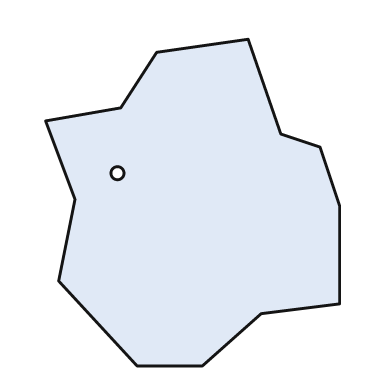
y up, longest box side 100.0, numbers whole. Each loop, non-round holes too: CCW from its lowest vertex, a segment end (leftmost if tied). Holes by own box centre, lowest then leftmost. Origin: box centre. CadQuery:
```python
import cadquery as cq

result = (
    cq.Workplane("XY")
    .moveTo(-17.0, -50.0)
    .lineTo(3.0, -50.0)
    .lineTo(21.0, -34.0)
    .lineTo(45.0, -31.0)
    .lineTo(45.0, -1.0)
    .lineTo(39.0, 17.0)
    .lineTo(27.0, 21.0)
    .lineTo(17.0, 50.0)
    .lineTo(-11.0, 46.0)
    .lineTo(-22.0, 29.0)
    .lineTo(-45.0, 25.0)
    .lineTo(-36.0, 1.0)
    .lineTo(-41.0, -24.0)
    .close()
    .moveTo(-23.0, 9.0)
    .circle(2.0)
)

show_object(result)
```